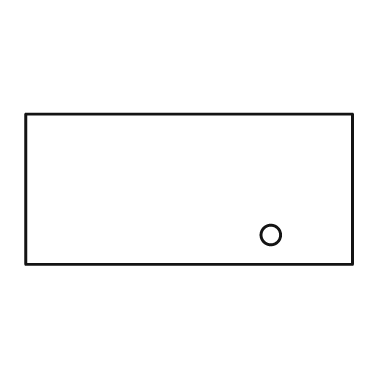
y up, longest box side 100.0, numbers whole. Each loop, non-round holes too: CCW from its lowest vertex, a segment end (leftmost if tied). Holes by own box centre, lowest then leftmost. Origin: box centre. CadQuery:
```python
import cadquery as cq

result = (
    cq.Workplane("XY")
    .moveTo(-50.0, -23.0)
    .lineTo(50.0, -23.0)
    .lineTo(50.0, 23.0)
    .lineTo(-50.0, 23.0)
    .close()
    .moveTo(25.0, -14.0)
    .circle(3.0)
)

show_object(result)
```